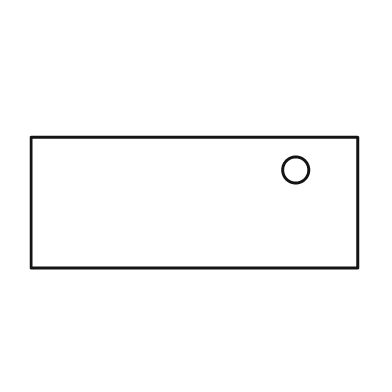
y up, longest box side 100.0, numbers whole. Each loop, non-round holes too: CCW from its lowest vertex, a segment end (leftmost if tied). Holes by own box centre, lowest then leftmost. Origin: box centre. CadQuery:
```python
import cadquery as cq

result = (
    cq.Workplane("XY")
    .moveTo(-50.0, -20.0)
    .lineTo(50.0, -20.0)
    .lineTo(50.0, 20.0)
    .lineTo(-50.0, 20.0)
    .close()
    .moveTo(31.0, 10.0)
    .circle(4.0)
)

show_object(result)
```